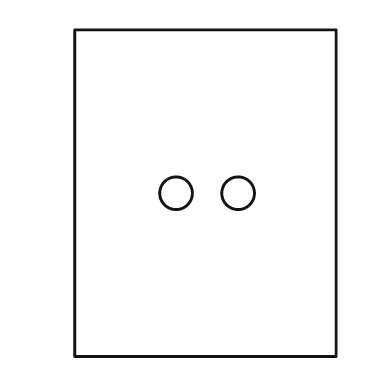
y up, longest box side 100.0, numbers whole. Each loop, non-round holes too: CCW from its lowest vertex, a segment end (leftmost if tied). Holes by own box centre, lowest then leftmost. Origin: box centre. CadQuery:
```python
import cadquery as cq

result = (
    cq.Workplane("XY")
    .moveTo(-40.0, -50.0)
    .lineTo(40.0, -50.0)
    .lineTo(40.0, 50.0)
    .lineTo(-40.0, 50.0)
    .close()
    .moveTo(-9.0, 0.0)
    .circle(5.0)
    .moveTo(10.0, 0.0)
    .circle(5.0)
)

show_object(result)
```